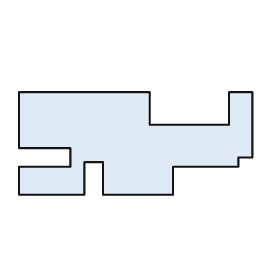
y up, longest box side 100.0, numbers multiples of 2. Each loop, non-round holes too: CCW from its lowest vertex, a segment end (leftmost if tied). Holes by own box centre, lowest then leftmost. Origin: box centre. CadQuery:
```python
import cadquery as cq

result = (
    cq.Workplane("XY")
    .moveTo(-50.0, -22.0)
    .lineTo(-22.0, -22.0)
    .lineTo(-22.0, -8.0)
    .lineTo(-14.0, -8.0)
    .lineTo(-14.0, -22.0)
    .lineTo(16.0, -22.0)
    .lineTo(16.0, -10.0)
    .lineTo(44.0, -10.0)
    .lineTo(44.0, -6.0)
    .lineTo(50.0, -6.0)
    .lineTo(50.0, 22.0)
    .lineTo(40.0, 22.0)
    .lineTo(40.0, 8.0)
    .lineTo(6.0, 8.0)
    .lineTo(6.0, 22.0)
    .lineTo(-50.0, 22.0)
    .lineTo(-50.0, -2.0)
    .lineTo(-28.0, -2.0)
    .lineTo(-28.0, -10.0)
    .lineTo(-50.0, -10.0)
    .close()
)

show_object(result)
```